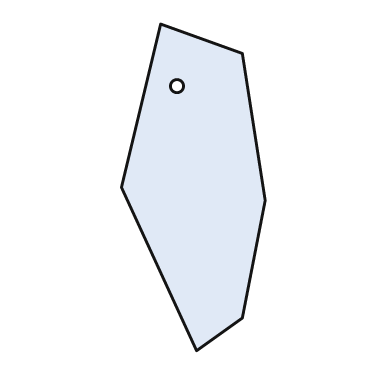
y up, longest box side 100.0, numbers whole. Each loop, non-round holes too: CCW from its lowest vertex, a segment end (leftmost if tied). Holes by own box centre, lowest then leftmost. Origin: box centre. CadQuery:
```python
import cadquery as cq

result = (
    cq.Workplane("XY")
    .moveTo(1.0, -50.0)
    .lineTo(15.0, -40.0)
    .lineTo(22.0, -4.0)
    .lineTo(15.0, 41.0)
    .lineTo(-10.0, 50.0)
    .lineTo(-22.0, 0.0)
    .close()
    .moveTo(-5.0, 31.0)
    .circle(2.0)
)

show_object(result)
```